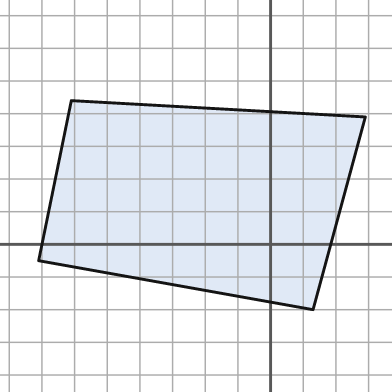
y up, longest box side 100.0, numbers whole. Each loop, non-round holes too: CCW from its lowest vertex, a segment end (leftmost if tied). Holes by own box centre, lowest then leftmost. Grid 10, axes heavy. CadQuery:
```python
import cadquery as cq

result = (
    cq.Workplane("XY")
    .moveTo(13.0, -20.0)
    .lineTo(29.0, 39.0)
    .lineTo(-61.0, 44.0)
    .lineTo(-71.0, -5.0)
    .close()
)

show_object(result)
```